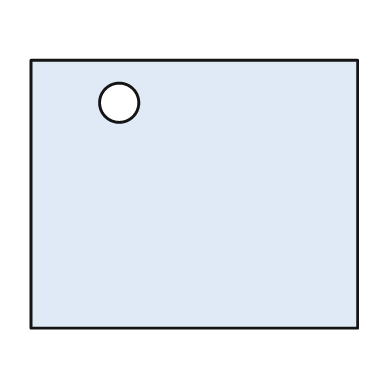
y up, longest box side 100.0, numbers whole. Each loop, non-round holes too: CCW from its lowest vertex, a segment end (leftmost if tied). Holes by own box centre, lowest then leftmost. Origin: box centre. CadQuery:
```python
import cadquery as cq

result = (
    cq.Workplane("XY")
    .moveTo(-50.0, -41.0)
    .lineTo(50.0, -41.0)
    .lineTo(50.0, 41.0)
    .lineTo(-50.0, 41.0)
    .close()
    .moveTo(-23.0, 28.0)
    .circle(6.0)
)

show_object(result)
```